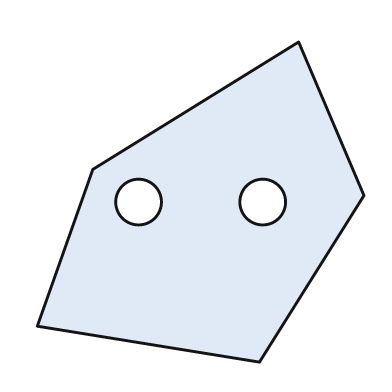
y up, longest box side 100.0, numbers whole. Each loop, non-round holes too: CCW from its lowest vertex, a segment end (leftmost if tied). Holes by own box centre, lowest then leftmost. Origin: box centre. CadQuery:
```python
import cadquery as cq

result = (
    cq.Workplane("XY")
    .moveTo(18.0, -49.0)
    .lineTo(50.0, 2.0)
    .lineTo(30.0, 49.0)
    .lineTo(-33.0, 10.0)
    .lineTo(-50.0, -38.0)
    .close()
    .moveTo(-19.0, 0.0)
    .circle(7.0)
    .moveTo(19.0, 0.0)
    .circle(7.0)
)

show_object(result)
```